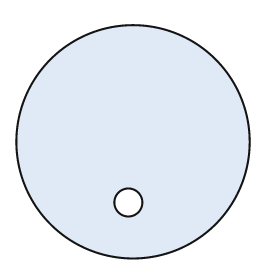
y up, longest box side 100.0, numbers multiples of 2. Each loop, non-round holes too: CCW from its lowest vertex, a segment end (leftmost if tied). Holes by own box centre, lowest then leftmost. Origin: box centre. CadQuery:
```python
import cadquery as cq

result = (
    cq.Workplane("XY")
    .moveTo(0.0, 0.0)
    .circle(50.0)
    .moveTo(-2.0, -26.0)
    .circle(6.0)
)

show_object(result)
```